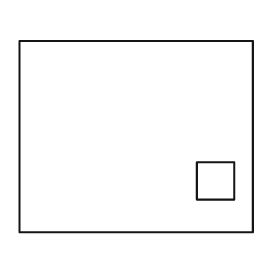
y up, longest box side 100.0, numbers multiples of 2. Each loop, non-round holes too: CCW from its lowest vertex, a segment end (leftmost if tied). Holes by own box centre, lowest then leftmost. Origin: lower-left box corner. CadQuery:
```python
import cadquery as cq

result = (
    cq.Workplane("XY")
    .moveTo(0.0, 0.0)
    .lineTo(100.0, 0.0)
    .lineTo(100.0, 82.0)
    .lineTo(0.0, 82.0)
    .close()
    .moveTo(76.0, 14.0)
    .lineTo(92.0, 14.0)
    .lineTo(92.0, 30.0)
    .lineTo(76.0, 30.0)
    .close()
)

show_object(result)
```